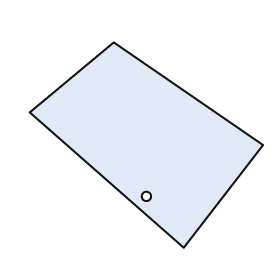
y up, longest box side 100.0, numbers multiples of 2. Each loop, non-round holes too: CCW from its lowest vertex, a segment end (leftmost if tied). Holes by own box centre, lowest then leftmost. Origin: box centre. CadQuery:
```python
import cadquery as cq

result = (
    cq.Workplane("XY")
    .moveTo(16.0, -44.0)
    .lineTo(50.0, 0.0)
    .lineTo(-14.0, 44.0)
    .lineTo(-50.0, 14.0)
    .close()
    .moveTo(0.0, -22.0)
    .circle(2.0)
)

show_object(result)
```